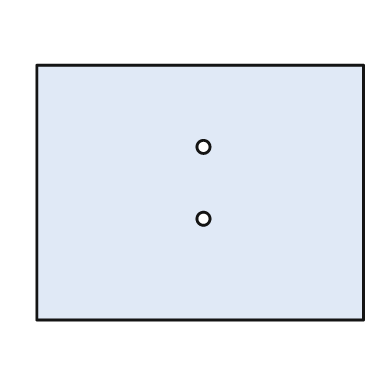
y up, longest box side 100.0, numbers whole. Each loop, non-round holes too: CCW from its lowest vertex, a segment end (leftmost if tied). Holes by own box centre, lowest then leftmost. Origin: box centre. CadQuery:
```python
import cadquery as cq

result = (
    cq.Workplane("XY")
    .moveTo(-50.0, -39.0)
    .lineTo(50.0, -39.0)
    .lineTo(50.0, 39.0)
    .lineTo(-50.0, 39.0)
    .close()
    .moveTo(1.0, -8.0)
    .circle(2.0)
    .moveTo(1.0, 14.0)
    .circle(2.0)
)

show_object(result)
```